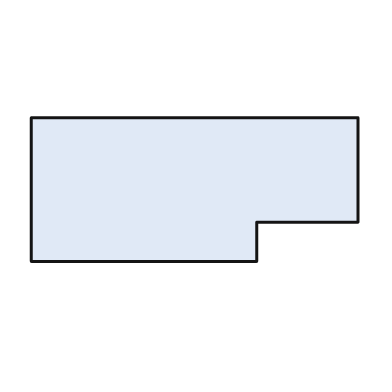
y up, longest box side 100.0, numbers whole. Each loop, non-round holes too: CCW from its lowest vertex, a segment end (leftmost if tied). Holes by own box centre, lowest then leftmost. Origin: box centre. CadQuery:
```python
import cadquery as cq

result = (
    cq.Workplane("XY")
    .moveTo(-50.0, -22.0)
    .lineTo(19.0, -22.0)
    .lineTo(19.0, -10.0)
    .lineTo(50.0, -10.0)
    .lineTo(50.0, 22.0)
    .lineTo(-50.0, 22.0)
    .close()
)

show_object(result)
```